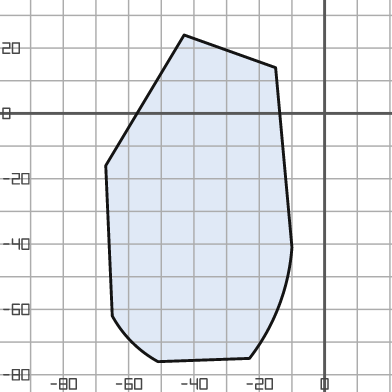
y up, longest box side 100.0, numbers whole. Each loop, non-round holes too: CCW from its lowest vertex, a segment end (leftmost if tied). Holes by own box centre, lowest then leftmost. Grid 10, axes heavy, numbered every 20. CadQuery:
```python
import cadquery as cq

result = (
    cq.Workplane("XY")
    .moveTo(-51.0, -76.0)
    .lineTo(-23.0, -75.0)
    .threePointArc((-14.0, -59.0), (-10.0, -41.0))
    .lineTo(-15.0, 14.0)
    .lineTo(-43.0, 24.0)
    .lineTo(-67.0, -16.0)
    .lineTo(-65.0, -62.0)
    .threePointArc((-59.0, -70.0), (-51.0, -76.0))
    .close()
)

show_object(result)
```